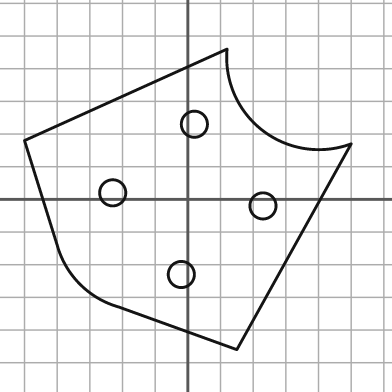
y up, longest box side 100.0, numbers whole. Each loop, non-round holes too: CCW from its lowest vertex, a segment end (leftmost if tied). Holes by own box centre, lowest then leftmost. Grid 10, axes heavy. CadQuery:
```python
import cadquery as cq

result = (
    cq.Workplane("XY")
    .moveTo(15.0, -46.0)
    .lineTo(50.0, 17.0)
    .threePointArc((23.0, 21.0), (12.0, 46.0))
    .lineTo(-50.0, 18.0)
    .lineTo(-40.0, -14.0)
    .threePointArc((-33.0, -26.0), (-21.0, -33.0))
    .close()
    .moveTo(-2.0, -23.0)
    .circle(4.0)
    .moveTo(23.0, -2.0)
    .circle(4.0)
    .moveTo(-23.0, 2.0)
    .circle(4.0)
    .moveTo(2.0, 23.0)
    .circle(4.0)
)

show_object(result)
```